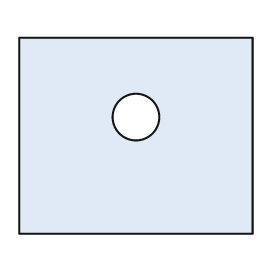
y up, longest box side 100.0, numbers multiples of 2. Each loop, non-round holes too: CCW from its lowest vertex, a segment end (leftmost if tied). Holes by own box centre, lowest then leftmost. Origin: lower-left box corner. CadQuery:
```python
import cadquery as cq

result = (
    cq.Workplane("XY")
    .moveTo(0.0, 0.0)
    .lineTo(100.0, 0.0)
    .lineTo(100.0, 84.0)
    .lineTo(0.0, 84.0)
    .close()
    .moveTo(50.0, 50.0)
    .circle(10.0)
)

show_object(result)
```